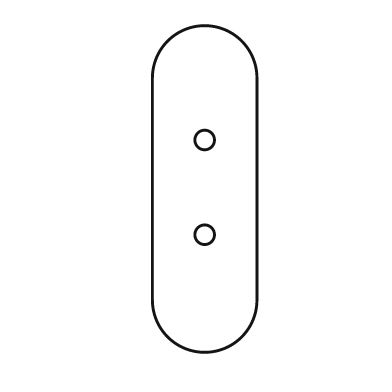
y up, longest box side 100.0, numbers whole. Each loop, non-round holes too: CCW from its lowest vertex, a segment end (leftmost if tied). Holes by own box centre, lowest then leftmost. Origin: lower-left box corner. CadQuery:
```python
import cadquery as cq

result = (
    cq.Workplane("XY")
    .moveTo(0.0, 16.0)
    .threePointArc((16.0, 0.0), (32.0, 16.0))
    .lineTo(32.0, 84.0)
    .threePointArc((16.0, 100.0), (0.0, 84.0))
    .close()
    .moveTo(16.0, 36.0)
    .circle(3.0)
    .moveTo(16.0, 65.0)
    .circle(3.0)
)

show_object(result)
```